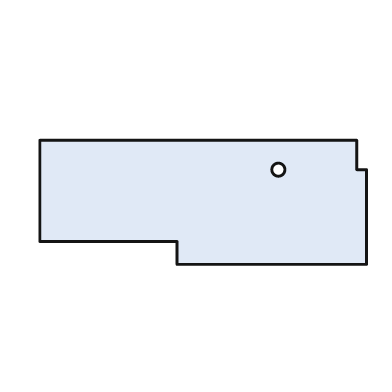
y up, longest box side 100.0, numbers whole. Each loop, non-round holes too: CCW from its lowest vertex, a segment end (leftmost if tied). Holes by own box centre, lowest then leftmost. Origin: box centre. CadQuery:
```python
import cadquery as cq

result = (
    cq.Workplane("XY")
    .moveTo(-8.0, -19.0)
    .lineTo(50.0, -19.0)
    .lineTo(50.0, 10.0)
    .lineTo(47.0, 10.0)
    .lineTo(47.0, 19.0)
    .lineTo(-50.0, 19.0)
    .lineTo(-50.0, -12.0)
    .lineTo(-8.0, -12.0)
    .close()
    .moveTo(23.0, 10.0)
    .circle(2.0)
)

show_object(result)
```